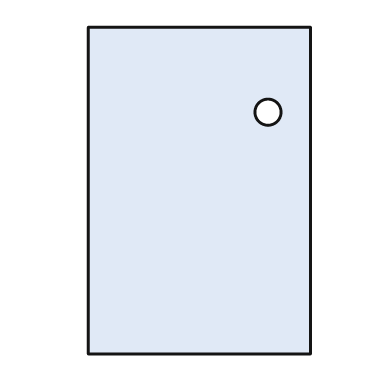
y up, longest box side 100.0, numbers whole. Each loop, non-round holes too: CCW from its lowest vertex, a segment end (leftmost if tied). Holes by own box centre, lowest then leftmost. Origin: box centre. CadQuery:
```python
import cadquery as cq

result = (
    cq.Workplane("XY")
    .moveTo(-34.0, -50.0)
    .lineTo(34.0, -50.0)
    .lineTo(34.0, 50.0)
    .lineTo(-34.0, 50.0)
    .close()
    .moveTo(21.0, 24.0)
    .circle(4.0)
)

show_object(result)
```